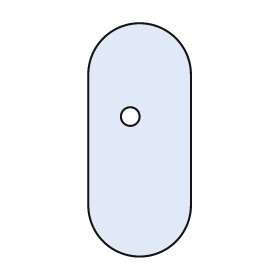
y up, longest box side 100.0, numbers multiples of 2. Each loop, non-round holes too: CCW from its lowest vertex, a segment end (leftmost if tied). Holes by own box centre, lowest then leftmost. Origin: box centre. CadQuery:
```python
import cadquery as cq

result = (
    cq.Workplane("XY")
    .moveTo(-22.0, -28.0)
    .threePointArc((0.0, -50.0), (22.0, -28.0))
    .lineTo(22.0, 28.0)
    .threePointArc((0.0, 50.0), (-22.0, 28.0))
    .close()
    .moveTo(-4.0, 10.0)
    .circle(4.0)
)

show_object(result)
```